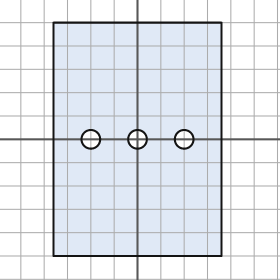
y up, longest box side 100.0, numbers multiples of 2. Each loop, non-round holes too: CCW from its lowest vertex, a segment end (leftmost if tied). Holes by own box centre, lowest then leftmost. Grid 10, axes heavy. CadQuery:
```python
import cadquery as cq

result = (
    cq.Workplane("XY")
    .moveTo(-36.0, -50.0)
    .lineTo(36.0, -50.0)
    .lineTo(36.0, 50.0)
    .lineTo(-36.0, 50.0)
    .close()
    .moveTo(-20.0, 0.0)
    .circle(4.0)
    .moveTo(0.0, 0.0)
    .circle(4.0)
    .moveTo(20.0, 0.0)
    .circle(4.0)
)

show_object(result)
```